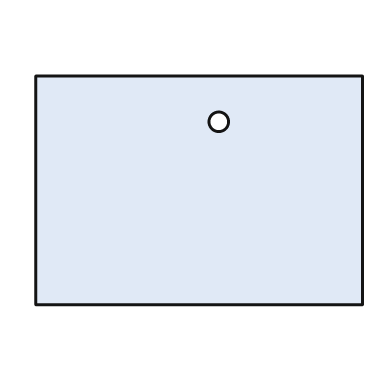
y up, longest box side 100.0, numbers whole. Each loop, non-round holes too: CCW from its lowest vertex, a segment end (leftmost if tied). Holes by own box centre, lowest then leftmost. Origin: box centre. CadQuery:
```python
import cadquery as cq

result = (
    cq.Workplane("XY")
    .moveTo(-50.0, -35.0)
    .lineTo(50.0, -35.0)
    .lineTo(50.0, 35.0)
    .lineTo(-50.0, 35.0)
    .close()
    .moveTo(6.0, 21.0)
    .circle(3.0)
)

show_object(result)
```